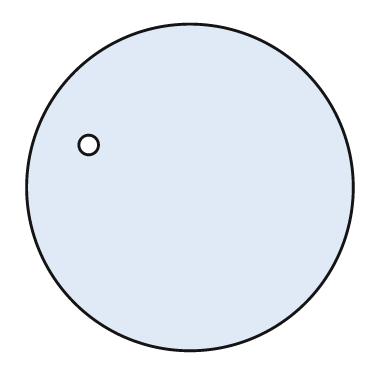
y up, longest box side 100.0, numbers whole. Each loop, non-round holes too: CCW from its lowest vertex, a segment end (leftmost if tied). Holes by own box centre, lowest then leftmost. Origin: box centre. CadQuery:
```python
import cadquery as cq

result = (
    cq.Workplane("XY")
    .moveTo(0.0, 0.0)
    .circle(50.0)
    .moveTo(-31.0, 13.0)
    .circle(3.0)
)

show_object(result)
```